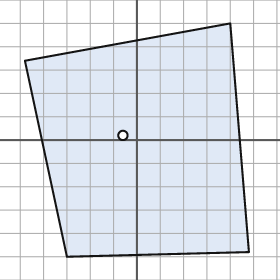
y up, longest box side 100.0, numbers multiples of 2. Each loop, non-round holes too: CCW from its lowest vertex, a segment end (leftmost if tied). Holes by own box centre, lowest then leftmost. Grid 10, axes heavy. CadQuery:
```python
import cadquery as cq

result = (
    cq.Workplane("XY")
    .moveTo(-30.0, -50.0)
    .lineTo(48.0, -48.0)
    .lineTo(40.0, 50.0)
    .lineTo(-48.0, 34.0)
    .close()
    .moveTo(-6.0, 2.0)
    .circle(2.0)
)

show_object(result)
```